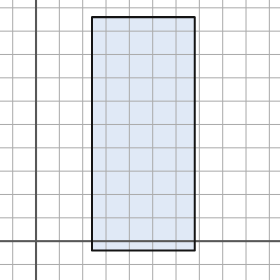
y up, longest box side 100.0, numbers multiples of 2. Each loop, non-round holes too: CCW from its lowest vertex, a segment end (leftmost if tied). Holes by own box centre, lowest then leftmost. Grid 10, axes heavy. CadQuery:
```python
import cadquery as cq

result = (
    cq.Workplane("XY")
    .moveTo(24.0, -4.0)
    .lineTo(68.0, -4.0)
    .lineTo(68.0, 96.0)
    .lineTo(24.0, 96.0)
    .close()
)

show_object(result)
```